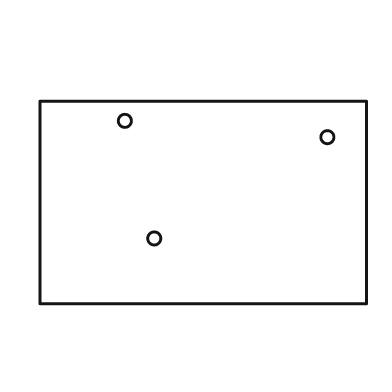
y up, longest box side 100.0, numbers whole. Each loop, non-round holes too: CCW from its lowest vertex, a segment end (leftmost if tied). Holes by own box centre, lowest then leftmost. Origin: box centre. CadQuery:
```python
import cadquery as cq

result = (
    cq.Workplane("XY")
    .moveTo(-50.0, -31.0)
    .lineTo(50.0, -31.0)
    .lineTo(50.0, 31.0)
    .lineTo(-50.0, 31.0)
    .close()
    .moveTo(-15.0, -11.0)
    .circle(2.0)
    .moveTo(38.0, 20.0)
    .circle(2.0)
    .moveTo(-24.0, 25.0)
    .circle(2.0)
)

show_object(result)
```